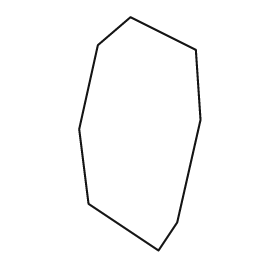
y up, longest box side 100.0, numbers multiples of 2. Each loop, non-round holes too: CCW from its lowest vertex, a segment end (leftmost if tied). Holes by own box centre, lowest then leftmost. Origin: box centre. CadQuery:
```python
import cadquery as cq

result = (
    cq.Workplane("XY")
    .moveTo(8.0, -50.0)
    .lineTo(16.0, -38.0)
    .lineTo(26.0, 6.0)
    .lineTo(24.0, 36.0)
    .lineTo(-4.0, 50.0)
    .lineTo(-18.0, 38.0)
    .lineTo(-26.0, 2.0)
    .lineTo(-22.0, -30.0)
    .close()
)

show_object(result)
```